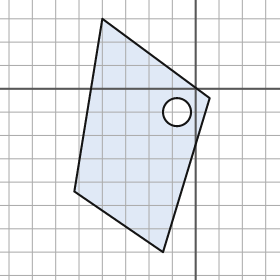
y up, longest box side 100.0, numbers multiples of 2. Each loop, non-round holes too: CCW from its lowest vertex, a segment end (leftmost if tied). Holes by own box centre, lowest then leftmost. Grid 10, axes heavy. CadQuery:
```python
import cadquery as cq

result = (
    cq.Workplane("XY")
    .moveTo(-14.0, -70.0)
    .lineTo(6.0, -4.0)
    .lineTo(-40.0, 30.0)
    .lineTo(-52.0, -44.0)
    .close()
    .moveTo(-8.0, -10.0)
    .circle(6.0)
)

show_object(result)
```